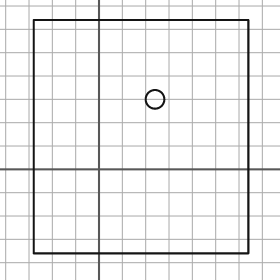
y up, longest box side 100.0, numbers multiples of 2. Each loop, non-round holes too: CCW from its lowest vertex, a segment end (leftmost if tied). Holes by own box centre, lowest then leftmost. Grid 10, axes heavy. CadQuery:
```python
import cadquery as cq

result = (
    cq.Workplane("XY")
    .moveTo(-28.0, -36.0)
    .lineTo(64.0, -36.0)
    .lineTo(64.0, 64.0)
    .lineTo(-28.0, 64.0)
    .close()
    .moveTo(24.0, 30.0)
    .circle(4.0)
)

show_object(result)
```